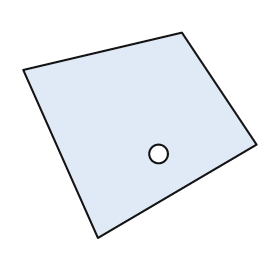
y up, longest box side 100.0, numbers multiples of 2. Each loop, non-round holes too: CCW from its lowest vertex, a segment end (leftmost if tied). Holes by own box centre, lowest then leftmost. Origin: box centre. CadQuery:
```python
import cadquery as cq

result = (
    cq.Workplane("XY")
    .moveTo(-18.0, -44.0)
    .lineTo(50.0, -4.0)
    .lineTo(18.0, 44.0)
    .lineTo(-50.0, 28.0)
    .close()
    .moveTo(8.0, -8.0)
    .circle(4.0)
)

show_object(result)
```